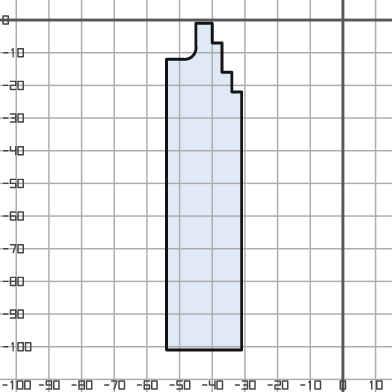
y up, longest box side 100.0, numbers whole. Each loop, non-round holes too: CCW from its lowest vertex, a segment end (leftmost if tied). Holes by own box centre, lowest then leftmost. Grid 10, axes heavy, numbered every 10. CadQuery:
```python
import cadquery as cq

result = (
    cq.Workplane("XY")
    .moveTo(-54.0, -101.0)
    .lineTo(-31.0, -101.0)
    .lineTo(-31.0, -22.0)
    .lineTo(-34.0, -22.0)
    .lineTo(-34.0, -16.0)
    .lineTo(-37.0, -16.0)
    .lineTo(-37.0, -7.0)
    .lineTo(-40.0, -7.0)
    .lineTo(-40.0, -1.0)
    .lineTo(-45.0, -1.0)
    .lineTo(-45.0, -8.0)
    .threePointArc((-46.0, -11.0), (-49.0, -12.0))
    .lineTo(-54.0, -12.0)
    .close()
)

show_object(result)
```